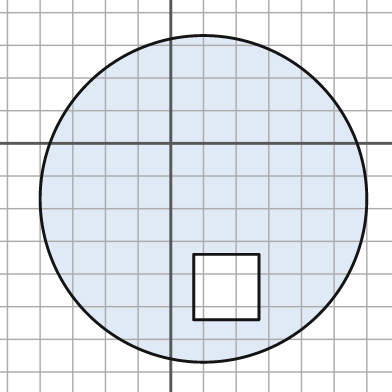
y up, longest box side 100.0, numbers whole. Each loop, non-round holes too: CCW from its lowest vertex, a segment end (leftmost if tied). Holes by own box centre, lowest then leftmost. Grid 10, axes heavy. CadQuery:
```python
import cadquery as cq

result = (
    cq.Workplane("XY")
    .moveTo(10.0, -17.0)
    .circle(50.0)
    .moveTo(7.0, -54.0)
    .lineTo(27.0, -54.0)
    .lineTo(27.0, -34.0)
    .lineTo(7.0, -34.0)
    .close()
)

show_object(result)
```